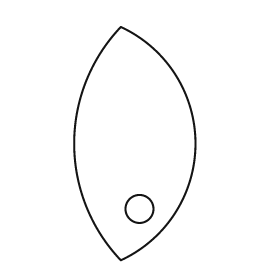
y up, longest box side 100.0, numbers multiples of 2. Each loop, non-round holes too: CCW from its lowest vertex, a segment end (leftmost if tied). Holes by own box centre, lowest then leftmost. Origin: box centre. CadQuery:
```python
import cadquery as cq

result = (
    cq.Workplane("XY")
    .moveTo(-6.0, -50.0)
    .threePointArc((26.0, 0.0), (-6.0, 50.0))
    .threePointArc((-26.0, 0.0), (-6.0, -50.0))
    .close()
    .moveTo(2.0, -28.0)
    .circle(6.0)
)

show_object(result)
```